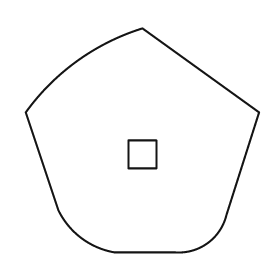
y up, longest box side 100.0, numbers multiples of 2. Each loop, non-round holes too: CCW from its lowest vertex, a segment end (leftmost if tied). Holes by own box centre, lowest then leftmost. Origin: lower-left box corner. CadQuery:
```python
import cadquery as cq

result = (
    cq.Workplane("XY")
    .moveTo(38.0, 0.0)
    .lineTo(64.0, 0.0)
    .threePointArc((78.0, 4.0), (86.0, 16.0))
    .lineTo(100.0, 60.0)
    .lineTo(50.0, 96.0)
    .threePointArc((22.0, 82.0), (0.0, 60.0))
    .lineTo(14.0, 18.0)
    .threePointArc((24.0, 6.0), (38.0, 0.0))
    .close()
    .moveTo(44.0, 36.0)
    .lineTo(56.0, 36.0)
    .lineTo(56.0, 48.0)
    .lineTo(44.0, 48.0)
    .close()
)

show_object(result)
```